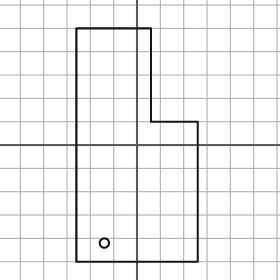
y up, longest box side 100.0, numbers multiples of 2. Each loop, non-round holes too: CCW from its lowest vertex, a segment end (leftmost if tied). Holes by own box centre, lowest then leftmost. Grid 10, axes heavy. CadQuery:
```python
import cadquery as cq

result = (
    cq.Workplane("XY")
    .moveTo(-26.0, -50.0)
    .lineTo(26.0, -50.0)
    .lineTo(26.0, 10.0)
    .lineTo(6.0, 10.0)
    .lineTo(6.0, 50.0)
    .lineTo(-26.0, 50.0)
    .close()
    .moveTo(-14.0, -42.0)
    .circle(2.0)
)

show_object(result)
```